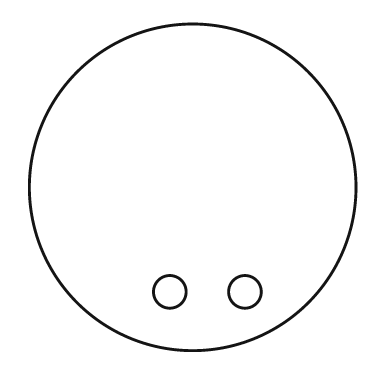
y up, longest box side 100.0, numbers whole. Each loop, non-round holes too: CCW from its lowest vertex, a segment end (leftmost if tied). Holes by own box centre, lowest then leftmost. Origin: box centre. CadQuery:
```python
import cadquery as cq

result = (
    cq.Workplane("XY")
    .moveTo(0.0, 0.0)
    .circle(50.0)
    .moveTo(-7.0, -32.0)
    .circle(5.0)
    .moveTo(16.0, -32.0)
    .circle(5.0)
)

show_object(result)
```